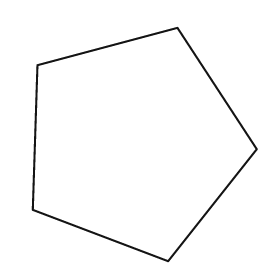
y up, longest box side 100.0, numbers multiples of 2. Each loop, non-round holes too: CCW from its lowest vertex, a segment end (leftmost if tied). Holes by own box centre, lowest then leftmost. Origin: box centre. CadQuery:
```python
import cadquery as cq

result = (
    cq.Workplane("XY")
    .moveTo(10.0, -50.0)
    .lineTo(48.0, -2.0)
    .lineTo(14.0, 50.0)
    .lineTo(-46.0, 34.0)
    .lineTo(-48.0, -28.0)
    .close()
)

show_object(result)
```